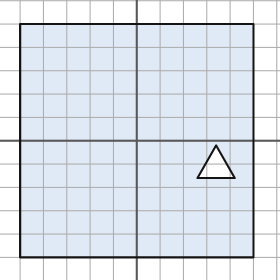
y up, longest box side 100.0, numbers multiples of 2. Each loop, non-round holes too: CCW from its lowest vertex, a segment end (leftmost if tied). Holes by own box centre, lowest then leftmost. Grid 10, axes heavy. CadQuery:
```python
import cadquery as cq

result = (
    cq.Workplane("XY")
    .moveTo(-50.0, -50.0)
    .lineTo(50.0, -50.0)
    .lineTo(50.0, 50.0)
    .lineTo(-50.0, 50.0)
    .close()
    .moveTo(26.0, -16.0)
    .lineTo(42.0, -16.0)
    .lineTo(34.0, -2.0)
    .close()
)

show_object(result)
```